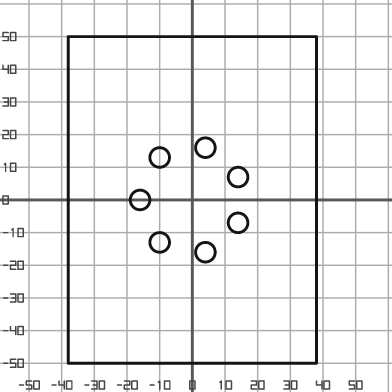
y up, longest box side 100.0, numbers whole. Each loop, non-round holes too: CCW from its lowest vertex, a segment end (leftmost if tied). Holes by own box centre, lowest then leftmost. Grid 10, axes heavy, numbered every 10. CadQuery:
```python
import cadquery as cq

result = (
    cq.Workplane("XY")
    .moveTo(-38.0, -50.0)
    .lineTo(38.0, -50.0)
    .lineTo(38.0, 50.0)
    .lineTo(-38.0, 50.0)
    .close()
    .moveTo(4.0, -16.0)
    .circle(3.0)
    .moveTo(-10.0, -13.0)
    .circle(3.0)
    .moveTo(14.0, -7.0)
    .circle(3.0)
    .moveTo(-16.0, 0.0)
    .circle(3.0)
    .moveTo(14.0, 7.0)
    .circle(3.0)
    .moveTo(-10.0, 13.0)
    .circle(3.0)
    .moveTo(4.0, 16.0)
    .circle(3.0)
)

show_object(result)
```